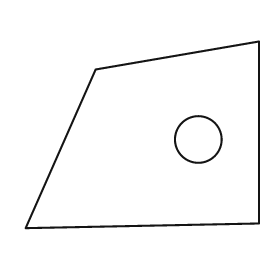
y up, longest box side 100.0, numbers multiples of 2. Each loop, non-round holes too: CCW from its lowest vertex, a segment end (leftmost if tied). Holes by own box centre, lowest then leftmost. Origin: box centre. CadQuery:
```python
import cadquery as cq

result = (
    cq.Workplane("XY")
    .moveTo(-50.0, -40.0)
    .lineTo(50.0, -38.0)
    .lineTo(50.0, 40.0)
    .lineTo(-20.0, 28.0)
    .close()
    .moveTo(24.0, -2.0)
    .circle(10.0)
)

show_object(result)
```